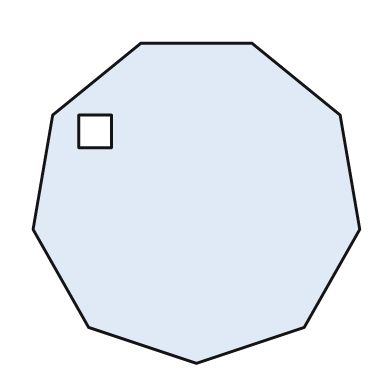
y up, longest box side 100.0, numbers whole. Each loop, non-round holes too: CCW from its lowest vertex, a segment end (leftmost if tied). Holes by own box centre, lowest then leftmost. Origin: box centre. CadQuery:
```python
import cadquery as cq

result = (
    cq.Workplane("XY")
    .moveTo(0.0, -49.0)
    .lineTo(33.0, -38.0)
    .lineTo(50.0, -8.0)
    .lineTo(44.0, 27.0)
    .lineTo(17.0, 49.0)
    .lineTo(-17.0, 49.0)
    .lineTo(-44.0, 27.0)
    .lineTo(-50.0, -8.0)
    .lineTo(-33.0, -38.0)
    .close()
    .moveTo(-36.0, 17.0)
    .lineTo(-26.0, 17.0)
    .lineTo(-26.0, 27.0)
    .lineTo(-36.0, 27.0)
    .close()
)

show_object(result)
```